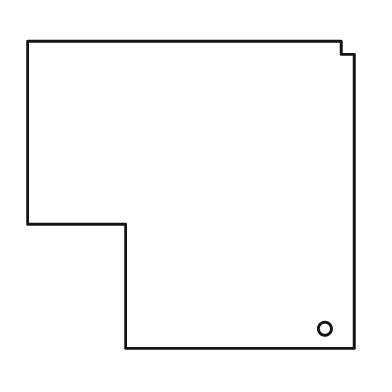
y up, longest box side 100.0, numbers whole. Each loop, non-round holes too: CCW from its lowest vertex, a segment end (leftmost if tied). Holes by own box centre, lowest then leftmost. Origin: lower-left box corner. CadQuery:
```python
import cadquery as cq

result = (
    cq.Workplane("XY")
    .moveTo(30.0, 0.0)
    .lineTo(100.0, 0.0)
    .lineTo(100.0, 90.0)
    .lineTo(96.0, 90.0)
    .lineTo(96.0, 94.0)
    .lineTo(0.0, 94.0)
    .lineTo(0.0, 38.0)
    .lineTo(30.0, 38.0)
    .close()
    .moveTo(91.0, 6.0)
    .circle(2.0)
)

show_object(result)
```